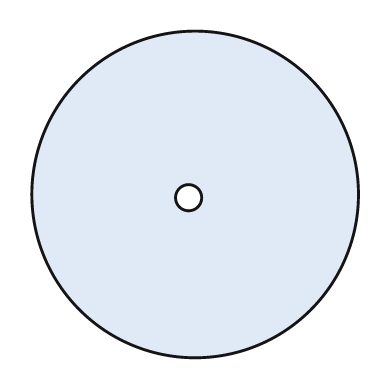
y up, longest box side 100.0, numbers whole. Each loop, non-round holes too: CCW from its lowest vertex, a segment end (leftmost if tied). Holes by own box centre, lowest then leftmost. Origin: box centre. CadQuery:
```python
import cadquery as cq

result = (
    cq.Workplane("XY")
    .moveTo(0.0, 0.0)
    .circle(50.0)
    .moveTo(-2.0, -1.0)
    .circle(4.0)
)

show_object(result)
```